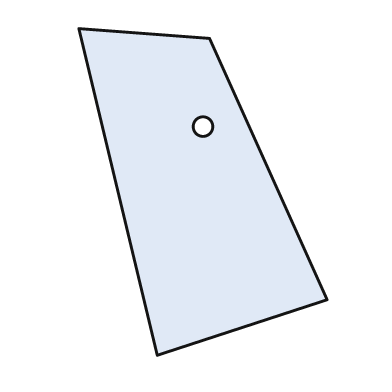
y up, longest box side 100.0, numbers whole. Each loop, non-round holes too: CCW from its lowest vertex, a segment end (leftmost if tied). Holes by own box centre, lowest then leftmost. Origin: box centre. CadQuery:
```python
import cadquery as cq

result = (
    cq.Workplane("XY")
    .moveTo(-14.0, -50.0)
    .lineTo(38.0, -33.0)
    .lineTo(2.0, 47.0)
    .lineTo(-38.0, 50.0)
    .close()
    .moveTo(0.0, 20.0)
    .circle(3.0)
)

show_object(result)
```